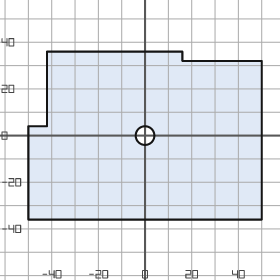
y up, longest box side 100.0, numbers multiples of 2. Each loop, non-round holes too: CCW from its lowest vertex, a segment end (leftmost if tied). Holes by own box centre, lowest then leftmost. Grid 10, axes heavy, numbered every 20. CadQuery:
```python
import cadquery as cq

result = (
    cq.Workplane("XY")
    .moveTo(-50.0, -36.0)
    .lineTo(50.0, -36.0)
    .lineTo(50.0, 32.0)
    .lineTo(16.0, 32.0)
    .lineTo(16.0, 36.0)
    .lineTo(-42.0, 36.0)
    .lineTo(-42.0, 4.0)
    .lineTo(-50.0, 4.0)
    .close()
    .moveTo(0.0, 0.0)
    .circle(4.0)
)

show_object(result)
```